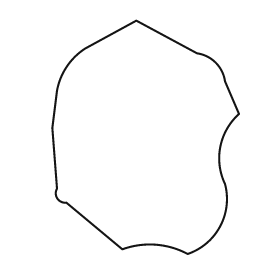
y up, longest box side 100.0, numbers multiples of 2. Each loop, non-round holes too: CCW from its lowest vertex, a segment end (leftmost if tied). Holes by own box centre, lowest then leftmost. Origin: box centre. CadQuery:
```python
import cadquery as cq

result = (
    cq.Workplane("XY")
    .moveTo(18.0, -50.0)
    .threePointArc((32.0, -38.0), (34.0, -20.0))
    .threePointArc((32.0, -4.0), (40.0, 10.0))
    .lineTo(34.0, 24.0)
    .threePointArc((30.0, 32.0), (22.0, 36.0))
    .lineTo(-4.0, 50.0)
    .lineTo(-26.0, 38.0)
    .threePointArc((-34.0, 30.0), (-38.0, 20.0))
    .lineTo(-40.0, 4.0)
    .lineTo(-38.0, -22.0)
    .threePointArc((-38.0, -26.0), (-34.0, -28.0))
    .lineTo(-10.0, -48.0)
    .threePointArc((4.0, -46.0), (18.0, -50.0))
    .close()
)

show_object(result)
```